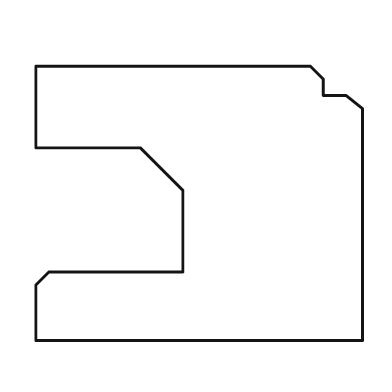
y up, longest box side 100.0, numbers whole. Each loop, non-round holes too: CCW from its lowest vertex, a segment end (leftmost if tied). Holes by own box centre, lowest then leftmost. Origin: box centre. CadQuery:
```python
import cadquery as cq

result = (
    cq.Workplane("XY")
    .moveTo(-50.0, -42.0)
    .lineTo(50.0, -42.0)
    .lineTo(50.0, 29.0)
    .lineTo(45.0, 33.0)
    .lineTo(38.0, 33.0)
    .lineTo(38.0, 38.0)
    .lineTo(34.0, 42.0)
    .lineTo(-50.0, 42.0)
    .lineTo(-50.0, 17.0)
    .lineTo(-18.0, 17.0)
    .lineTo(-5.0, 4.0)
    .lineTo(-5.0, -21.0)
    .lineTo(-46.0, -21.0)
    .lineTo(-50.0, -25.0)
    .close()
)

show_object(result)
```